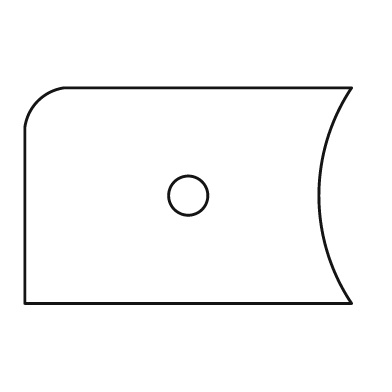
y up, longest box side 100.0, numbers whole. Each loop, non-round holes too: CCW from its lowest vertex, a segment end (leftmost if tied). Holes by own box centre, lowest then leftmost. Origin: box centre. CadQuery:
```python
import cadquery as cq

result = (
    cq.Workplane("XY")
    .moveTo(-50.0, -33.0)
    .lineTo(50.0, -33.0)
    .threePointArc((40.0, 0.0), (50.0, 33.0))
    .lineTo(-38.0, 33.0)
    .threePointArc((-46.0, 29.0), (-50.0, 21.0))
    .close()
    .moveTo(0.0, 0.0)
    .circle(6.0)
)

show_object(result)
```